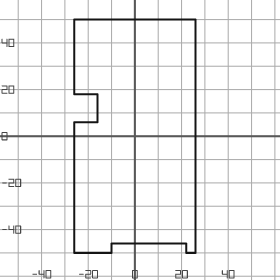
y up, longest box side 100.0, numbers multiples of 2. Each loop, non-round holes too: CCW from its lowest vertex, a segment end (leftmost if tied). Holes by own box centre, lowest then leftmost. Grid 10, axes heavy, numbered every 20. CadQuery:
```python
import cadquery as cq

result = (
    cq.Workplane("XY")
    .moveTo(-26.0, -50.0)
    .lineTo(-10.0, -50.0)
    .lineTo(-10.0, -46.0)
    .lineTo(22.0, -46.0)
    .lineTo(22.0, -50.0)
    .lineTo(26.0, -50.0)
    .lineTo(26.0, 50.0)
    .lineTo(-26.0, 50.0)
    .lineTo(-26.0, 18.0)
    .lineTo(-16.0, 18.0)
    .lineTo(-16.0, 6.0)
    .lineTo(-26.0, 6.0)
    .close()
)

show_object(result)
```